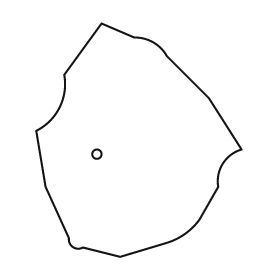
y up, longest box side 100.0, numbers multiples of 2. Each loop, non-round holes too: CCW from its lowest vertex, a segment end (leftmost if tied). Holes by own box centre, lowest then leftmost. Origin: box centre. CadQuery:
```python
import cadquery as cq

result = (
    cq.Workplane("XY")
    .moveTo(-8.0, -50.0)
    .lineTo(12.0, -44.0)
    .threePointArc((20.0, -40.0), (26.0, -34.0))
    .lineTo(34.0, -20.0)
    .threePointArc((36.0, -10.0), (44.0, -4.0))
    .lineTo(30.0, 18.0)
    .lineTo(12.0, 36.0)
    .threePointArc((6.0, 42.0), (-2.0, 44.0))
    .lineTo(-16.0, 50.0)
    .lineTo(-32.0, 28.0)
    .threePointArc((-34.0, 14.0), (-44.0, 4.0))
    .lineTo(-40.0, -20.0)
    .lineTo(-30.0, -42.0)
    .threePointArc((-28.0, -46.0), (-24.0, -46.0))
    .close()
    .moveTo(-18.0, -6.0)
    .circle(2.0)
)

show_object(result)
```